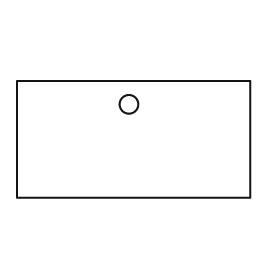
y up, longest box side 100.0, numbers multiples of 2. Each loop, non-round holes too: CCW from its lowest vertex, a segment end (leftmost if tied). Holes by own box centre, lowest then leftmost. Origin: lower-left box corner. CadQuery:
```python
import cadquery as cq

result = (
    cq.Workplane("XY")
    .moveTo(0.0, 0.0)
    .lineTo(100.0, 0.0)
    .lineTo(100.0, 50.0)
    .lineTo(0.0, 50.0)
    .close()
    .moveTo(48.0, 40.0)
    .circle(4.0)
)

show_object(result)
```